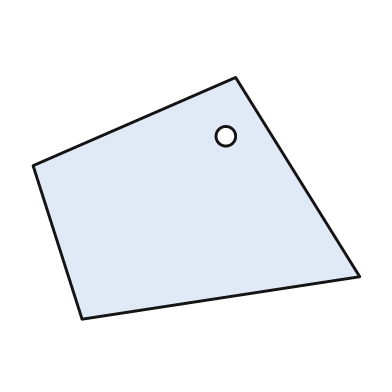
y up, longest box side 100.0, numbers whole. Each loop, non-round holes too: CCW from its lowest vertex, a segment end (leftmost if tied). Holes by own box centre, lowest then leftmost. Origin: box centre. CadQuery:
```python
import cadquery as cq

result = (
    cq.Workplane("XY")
    .moveTo(-35.0, -37.0)
    .lineTo(50.0, -24.0)
    .lineTo(12.0, 37.0)
    .lineTo(-50.0, 10.0)
    .close()
    .moveTo(9.0, 19.0)
    .circle(3.0)
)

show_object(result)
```